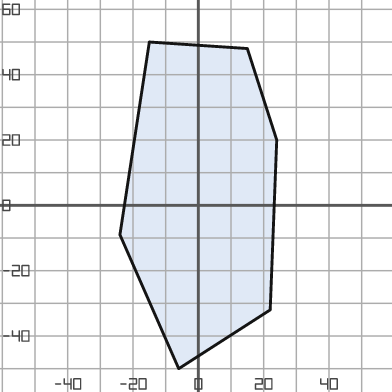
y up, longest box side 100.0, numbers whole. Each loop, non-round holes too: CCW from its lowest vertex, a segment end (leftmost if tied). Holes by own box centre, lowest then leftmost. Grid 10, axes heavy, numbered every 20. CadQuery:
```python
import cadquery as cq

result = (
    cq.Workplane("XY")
    .moveTo(-6.0, -50.0)
    .lineTo(22.0, -32.0)
    .lineTo(24.0, 20.0)
    .lineTo(15.0, 48.0)
    .lineTo(-15.0, 50.0)
    .lineTo(-24.0, -9.0)
    .close()
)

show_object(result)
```